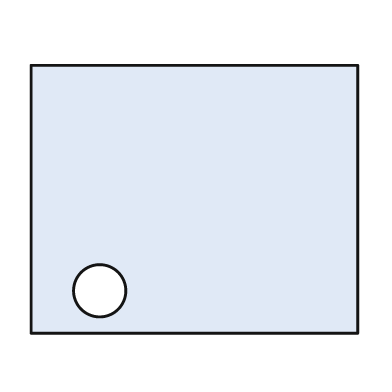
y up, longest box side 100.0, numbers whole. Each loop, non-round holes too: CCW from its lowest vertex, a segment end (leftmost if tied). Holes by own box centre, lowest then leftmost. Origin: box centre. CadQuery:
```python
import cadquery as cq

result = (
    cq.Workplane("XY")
    .moveTo(-50.0, -41.0)
    .lineTo(50.0, -41.0)
    .lineTo(50.0, 41.0)
    .lineTo(-50.0, 41.0)
    .close()
    .moveTo(-29.0, -28.0)
    .circle(8.0)
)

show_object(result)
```